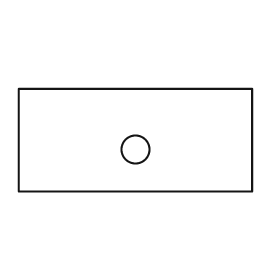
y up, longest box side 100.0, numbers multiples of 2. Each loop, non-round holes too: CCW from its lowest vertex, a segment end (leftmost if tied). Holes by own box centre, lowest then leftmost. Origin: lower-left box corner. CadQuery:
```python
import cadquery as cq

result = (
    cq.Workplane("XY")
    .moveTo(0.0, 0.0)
    .lineTo(100.0, 0.0)
    .lineTo(100.0, 44.0)
    .lineTo(0.0, 44.0)
    .close()
    .moveTo(50.0, 18.0)
    .circle(6.0)
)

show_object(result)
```